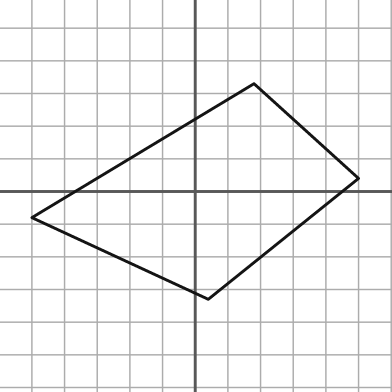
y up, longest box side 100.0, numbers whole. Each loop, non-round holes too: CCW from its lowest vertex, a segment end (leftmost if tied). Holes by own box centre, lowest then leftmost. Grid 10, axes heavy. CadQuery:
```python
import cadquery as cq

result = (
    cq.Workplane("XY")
    .moveTo(4.0, -33.0)
    .lineTo(50.0, 4.0)
    .lineTo(18.0, 33.0)
    .lineTo(-50.0, -8.0)
    .close()
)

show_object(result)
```